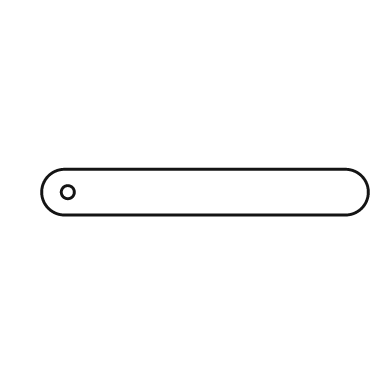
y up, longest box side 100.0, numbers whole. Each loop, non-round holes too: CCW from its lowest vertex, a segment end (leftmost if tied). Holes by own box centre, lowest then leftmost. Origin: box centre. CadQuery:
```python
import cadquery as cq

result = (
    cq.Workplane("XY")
    .moveTo(-43.0, -7.0)
    .lineTo(43.0, -7.0)
    .threePointArc((50.0, 0.0), (43.0, 7.0))
    .lineTo(-43.0, 7.0)
    .threePointArc((-50.0, 0.0), (-43.0, -7.0))
    .close()
    .moveTo(-42.0, 0.0)
    .circle(2.0)
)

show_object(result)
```